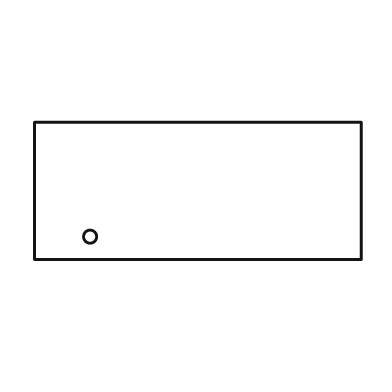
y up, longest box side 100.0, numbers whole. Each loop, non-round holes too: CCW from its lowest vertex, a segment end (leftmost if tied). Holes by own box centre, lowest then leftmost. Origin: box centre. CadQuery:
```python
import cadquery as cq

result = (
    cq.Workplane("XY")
    .moveTo(-50.0, -21.0)
    .lineTo(50.0, -21.0)
    .lineTo(50.0, 21.0)
    .lineTo(-50.0, 21.0)
    .close()
    .moveTo(-33.0, -14.0)
    .circle(2.0)
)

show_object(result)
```